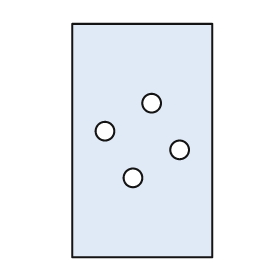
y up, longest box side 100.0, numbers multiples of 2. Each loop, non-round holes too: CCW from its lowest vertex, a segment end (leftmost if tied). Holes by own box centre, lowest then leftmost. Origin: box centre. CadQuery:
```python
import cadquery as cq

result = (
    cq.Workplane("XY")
    .moveTo(-30.0, -50.0)
    .lineTo(30.0, -50.0)
    .lineTo(30.0, 50.0)
    .lineTo(-30.0, 50.0)
    .close()
    .moveTo(-4.0, -16.0)
    .circle(4.0)
    .moveTo(16.0, -4.0)
    .circle(4.0)
    .moveTo(-16.0, 4.0)
    .circle(4.0)
    .moveTo(4.0, 16.0)
    .circle(4.0)
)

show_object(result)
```